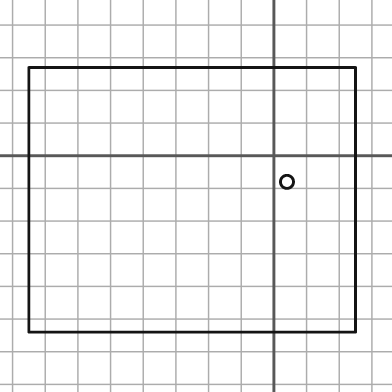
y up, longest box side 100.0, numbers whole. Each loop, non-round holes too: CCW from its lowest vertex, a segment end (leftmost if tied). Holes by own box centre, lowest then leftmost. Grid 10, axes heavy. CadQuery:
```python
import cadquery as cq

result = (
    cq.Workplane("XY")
    .moveTo(-75.0, -54.0)
    .lineTo(25.0, -54.0)
    .lineTo(25.0, 27.0)
    .lineTo(-75.0, 27.0)
    .close()
    .moveTo(4.0, -8.0)
    .circle(2.0)
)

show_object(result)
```